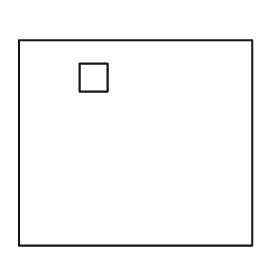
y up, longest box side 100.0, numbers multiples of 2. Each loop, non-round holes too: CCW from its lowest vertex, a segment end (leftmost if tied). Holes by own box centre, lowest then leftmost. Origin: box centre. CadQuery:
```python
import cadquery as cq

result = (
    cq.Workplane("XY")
    .moveTo(-50.0, -44.0)
    .lineTo(50.0, -44.0)
    .lineTo(50.0, 44.0)
    .lineTo(-50.0, 44.0)
    .close()
    .moveTo(-24.0, 22.0)
    .lineTo(-12.0, 22.0)
    .lineTo(-12.0, 34.0)
    .lineTo(-24.0, 34.0)
    .close()
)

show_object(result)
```